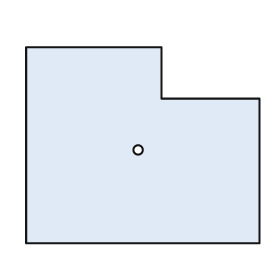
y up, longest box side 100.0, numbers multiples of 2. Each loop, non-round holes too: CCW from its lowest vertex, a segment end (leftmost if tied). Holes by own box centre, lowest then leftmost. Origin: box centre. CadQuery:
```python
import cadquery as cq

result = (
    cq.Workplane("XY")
    .moveTo(-50.0, -42.0)
    .lineTo(50.0, -42.0)
    .lineTo(50.0, 20.0)
    .lineTo(8.0, 20.0)
    .lineTo(8.0, 42.0)
    .lineTo(-50.0, 42.0)
    .close()
    .moveTo(-2.0, -2.0)
    .circle(2.0)
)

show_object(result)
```